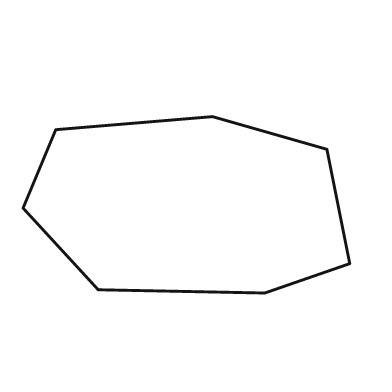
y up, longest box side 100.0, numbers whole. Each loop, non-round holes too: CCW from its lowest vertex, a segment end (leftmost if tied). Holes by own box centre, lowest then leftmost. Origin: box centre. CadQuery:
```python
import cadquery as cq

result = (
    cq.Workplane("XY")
    .moveTo(24.0, -27.0)
    .lineTo(50.0, -18.0)
    .lineTo(43.0, 17.0)
    .lineTo(8.0, 27.0)
    .lineTo(-40.0, 23.0)
    .lineTo(-50.0, -1.0)
    .lineTo(-27.0, -26.0)
    .close()
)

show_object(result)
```